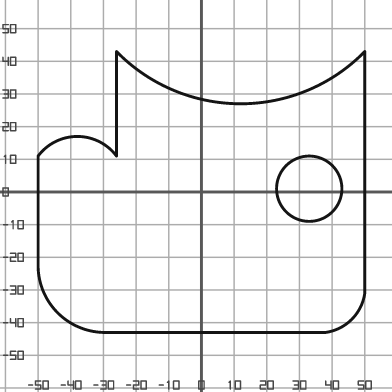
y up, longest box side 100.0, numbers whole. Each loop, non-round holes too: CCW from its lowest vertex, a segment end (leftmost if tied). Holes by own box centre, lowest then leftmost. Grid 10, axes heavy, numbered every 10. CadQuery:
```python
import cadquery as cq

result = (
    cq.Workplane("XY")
    .moveTo(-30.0, -43.0)
    .lineTo(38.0, -43.0)
    .threePointArc((46.0, -39.0), (50.0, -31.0))
    .lineTo(50.0, 43.0)
    .threePointArc((12.0, 27.0), (-26.0, 43.0))
    .lineTo(-26.0, 11.0)
    .threePointArc((-38.0, 17.0), (-50.0, 11.0))
    .lineTo(-50.0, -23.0)
    .threePointArc((-44.0, -37.0), (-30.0, -43.0))
    .close()
    .moveTo(33.0, 1.0)
    .circle(10.0)
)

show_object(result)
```